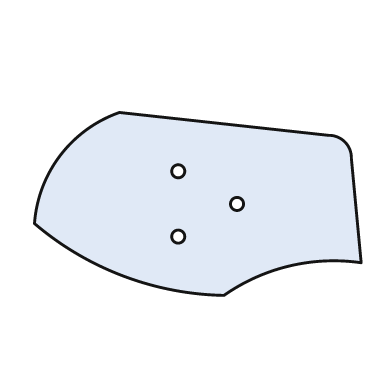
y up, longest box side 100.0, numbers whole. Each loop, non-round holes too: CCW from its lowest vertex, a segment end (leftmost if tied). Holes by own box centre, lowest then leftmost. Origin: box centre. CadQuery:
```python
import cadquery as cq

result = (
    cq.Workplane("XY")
    .moveTo(8.0, -28.0)
    .threePointArc((28.0, -19.0), (50.0, -18.0))
    .lineTo(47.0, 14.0)
    .threePointArc((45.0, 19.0), (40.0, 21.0))
    .lineTo(-24.0, 28.0)
    .threePointArc((-42.0, 15.0), (-50.0, -6.0))
    .threePointArc((-23.0, -22.0), (8.0, -28.0))
    .close()
    .moveTo(-6.0, -10.0)
    .circle(2.0)
    .moveTo(12.0, 0.0)
    .circle(2.0)
    .moveTo(-6.0, 10.0)
    .circle(2.0)
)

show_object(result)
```